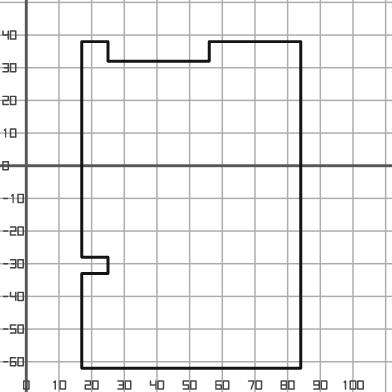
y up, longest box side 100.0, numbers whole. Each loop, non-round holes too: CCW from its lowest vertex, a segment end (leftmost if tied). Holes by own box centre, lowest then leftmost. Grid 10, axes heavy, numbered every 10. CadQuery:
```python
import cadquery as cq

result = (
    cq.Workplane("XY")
    .moveTo(17.0, -62.0)
    .lineTo(84.0, -62.0)
    .lineTo(84.0, 38.0)
    .lineTo(56.0, 38.0)
    .lineTo(56.0, 32.0)
    .lineTo(25.0, 32.0)
    .lineTo(25.0, 38.0)
    .lineTo(17.0, 38.0)
    .lineTo(17.0, -28.0)
    .lineTo(25.0, -28.0)
    .lineTo(25.0, -33.0)
    .lineTo(17.0, -33.0)
    .close()
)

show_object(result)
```